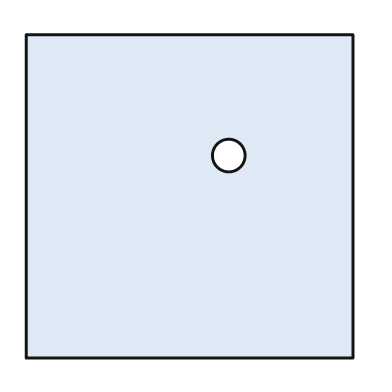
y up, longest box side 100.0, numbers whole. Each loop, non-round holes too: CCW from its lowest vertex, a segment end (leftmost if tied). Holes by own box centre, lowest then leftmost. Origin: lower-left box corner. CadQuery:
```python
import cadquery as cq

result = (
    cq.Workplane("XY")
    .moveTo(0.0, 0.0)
    .lineTo(100.0, 0.0)
    .lineTo(100.0, 99.0)
    .lineTo(0.0, 99.0)
    .close()
    .moveTo(62.0, 62.0)
    .circle(5.0)
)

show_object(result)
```